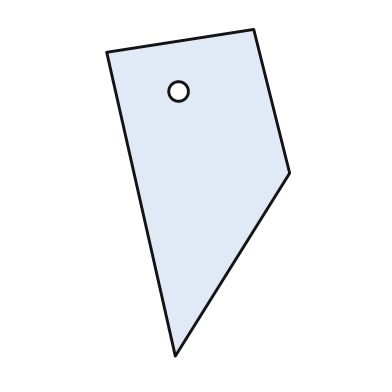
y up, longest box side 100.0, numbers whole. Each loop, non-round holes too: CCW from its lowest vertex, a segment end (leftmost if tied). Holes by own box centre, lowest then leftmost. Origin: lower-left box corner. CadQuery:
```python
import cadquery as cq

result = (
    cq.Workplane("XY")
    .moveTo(21.0, 0.0)
    .lineTo(56.0, 56.0)
    .lineTo(45.0, 100.0)
    .lineTo(0.0, 93.0)
    .close()
    .moveTo(22.0, 81.0)
    .circle(3.0)
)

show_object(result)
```